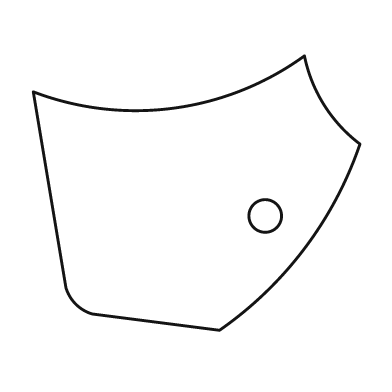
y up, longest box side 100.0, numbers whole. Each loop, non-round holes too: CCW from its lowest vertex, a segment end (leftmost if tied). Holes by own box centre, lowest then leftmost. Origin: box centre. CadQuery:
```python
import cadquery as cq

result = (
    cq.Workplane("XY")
    .moveTo(7.0, -42.0)
    .threePointArc((33.0, -17.0), (50.0, 15.0))
    .threePointArc((39.0, 27.0), (33.0, 42.0))
    .threePointArc((-7.0, 26.0), (-50.0, 31.0))
    .lineTo(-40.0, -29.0)
    .threePointArc((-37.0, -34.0), (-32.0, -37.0))
    .close()
    .moveTo(21.0, -7.0)
    .circle(5.0)
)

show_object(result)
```